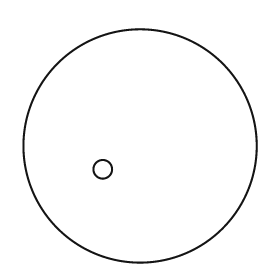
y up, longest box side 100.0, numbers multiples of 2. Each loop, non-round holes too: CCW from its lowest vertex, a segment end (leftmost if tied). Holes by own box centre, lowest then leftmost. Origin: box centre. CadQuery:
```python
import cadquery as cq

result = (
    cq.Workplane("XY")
    .moveTo(0.0, 0.0)
    .circle(50.0)
    .moveTo(-16.0, -10.0)
    .circle(4.0)
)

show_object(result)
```